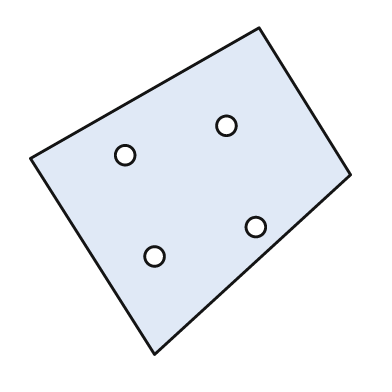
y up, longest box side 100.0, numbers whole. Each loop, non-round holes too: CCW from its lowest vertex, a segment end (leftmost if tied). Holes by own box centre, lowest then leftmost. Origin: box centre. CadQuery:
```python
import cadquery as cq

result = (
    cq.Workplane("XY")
    .moveTo(-11.0, -50.0)
    .lineTo(49.0, 5.0)
    .lineTo(21.0, 50.0)
    .lineTo(-49.0, 10.0)
    .close()
    .moveTo(-11.0, -20.0)
    .circle(3.0)
    .moveTo(20.0, -11.0)
    .circle(3.0)
    .moveTo(-20.0, 11.0)
    .circle(3.0)
    .moveTo(11.0, 20.0)
    .circle(3.0)
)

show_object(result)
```